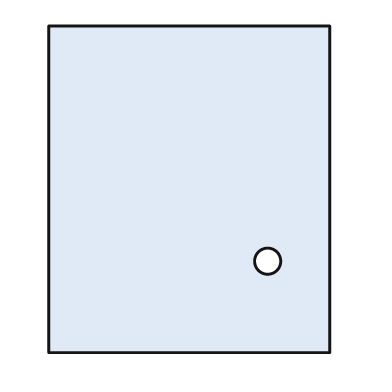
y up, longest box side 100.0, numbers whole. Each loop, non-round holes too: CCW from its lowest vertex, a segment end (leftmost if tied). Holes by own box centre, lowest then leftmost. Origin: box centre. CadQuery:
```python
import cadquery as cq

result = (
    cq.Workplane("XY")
    .moveTo(-43.0, -50.0)
    .lineTo(43.0, -50.0)
    .lineTo(43.0, 50.0)
    .lineTo(-43.0, 50.0)
    .close()
    .moveTo(24.0, -22.0)
    .circle(4.0)
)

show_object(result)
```